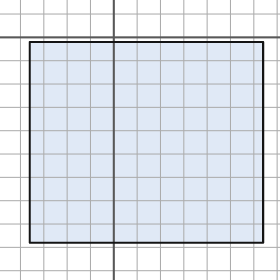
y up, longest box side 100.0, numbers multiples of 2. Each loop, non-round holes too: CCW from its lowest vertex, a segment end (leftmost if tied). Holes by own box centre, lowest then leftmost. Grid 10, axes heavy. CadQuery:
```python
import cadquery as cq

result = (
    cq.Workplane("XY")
    .moveTo(-36.0, -88.0)
    .lineTo(64.0, -88.0)
    .lineTo(64.0, -2.0)
    .lineTo(-36.0, -2.0)
    .close()
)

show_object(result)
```